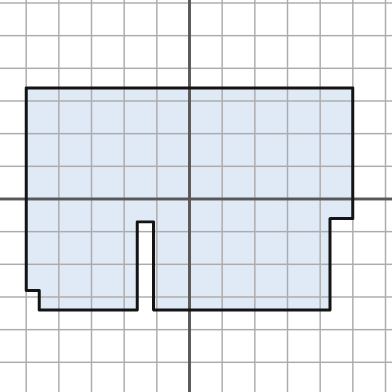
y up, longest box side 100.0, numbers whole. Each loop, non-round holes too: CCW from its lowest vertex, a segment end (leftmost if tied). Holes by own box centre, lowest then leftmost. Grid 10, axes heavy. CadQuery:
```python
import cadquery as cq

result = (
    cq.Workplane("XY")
    .moveTo(-46.0, -34.0)
    .lineTo(-16.0, -34.0)
    .lineTo(-16.0, -7.0)
    .lineTo(-11.0, -7.0)
    .lineTo(-11.0, -34.0)
    .lineTo(43.0, -34.0)
    .lineTo(43.0, -6.0)
    .lineTo(50.0, -6.0)
    .lineTo(50.0, 34.0)
    .lineTo(-50.0, 34.0)
    .lineTo(-50.0, -28.0)
    .lineTo(-46.0, -28.0)
    .close()
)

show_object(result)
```